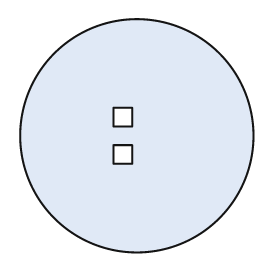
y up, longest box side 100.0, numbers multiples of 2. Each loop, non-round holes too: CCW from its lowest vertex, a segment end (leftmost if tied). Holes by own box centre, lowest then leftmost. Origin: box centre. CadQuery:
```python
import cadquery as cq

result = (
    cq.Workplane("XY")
    .moveTo(0.0, 0.0)
    .circle(50.0)
    .moveTo(-10.0, -12.0)
    .lineTo(-2.0, -12.0)
    .lineTo(-2.0, -4.0)
    .lineTo(-10.0, -4.0)
    .close()
    .moveTo(-10.0, 4.0)
    .lineTo(-2.0, 4.0)
    .lineTo(-2.0, 12.0)
    .lineTo(-10.0, 12.0)
    .close()
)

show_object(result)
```